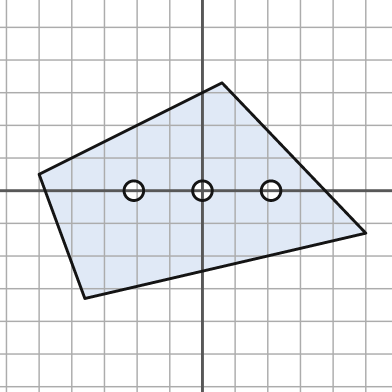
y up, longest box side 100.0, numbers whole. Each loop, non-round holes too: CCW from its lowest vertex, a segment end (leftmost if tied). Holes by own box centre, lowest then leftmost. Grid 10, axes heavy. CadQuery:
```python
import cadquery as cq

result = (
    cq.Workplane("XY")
    .moveTo(-36.0, -33.0)
    .lineTo(50.0, -13.0)
    .lineTo(6.0, 33.0)
    .lineTo(-50.0, 5.0)
    .close()
    .moveTo(-21.0, 0.0)
    .circle(3.0)
    .moveTo(0.0, 0.0)
    .circle(3.0)
    .moveTo(21.0, 0.0)
    .circle(3.0)
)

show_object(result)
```